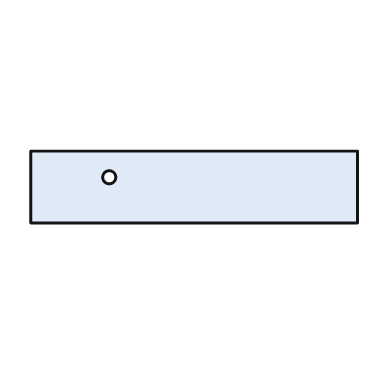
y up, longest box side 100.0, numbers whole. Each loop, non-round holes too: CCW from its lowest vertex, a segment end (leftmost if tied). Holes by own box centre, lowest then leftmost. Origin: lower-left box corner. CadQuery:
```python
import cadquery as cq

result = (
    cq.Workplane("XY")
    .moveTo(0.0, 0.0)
    .lineTo(100.0, 0.0)
    .lineTo(100.0, 22.0)
    .lineTo(0.0, 22.0)
    .close()
    .moveTo(24.0, 14.0)
    .circle(2.0)
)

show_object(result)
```